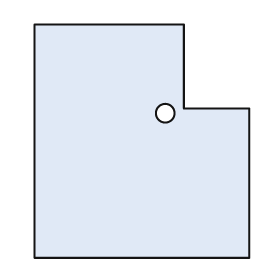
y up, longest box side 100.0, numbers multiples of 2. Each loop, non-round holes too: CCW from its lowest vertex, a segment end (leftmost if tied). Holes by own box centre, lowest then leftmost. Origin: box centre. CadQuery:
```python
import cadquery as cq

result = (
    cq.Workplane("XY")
    .moveTo(-46.0, -50.0)
    .lineTo(46.0, -50.0)
    .lineTo(46.0, 14.0)
    .lineTo(18.0, 14.0)
    .lineTo(18.0, 50.0)
    .lineTo(-46.0, 50.0)
    .close()
    .moveTo(10.0, 12.0)
    .circle(4.0)
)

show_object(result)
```